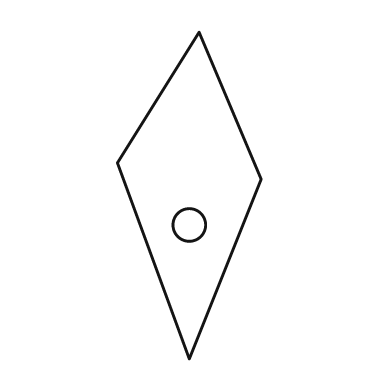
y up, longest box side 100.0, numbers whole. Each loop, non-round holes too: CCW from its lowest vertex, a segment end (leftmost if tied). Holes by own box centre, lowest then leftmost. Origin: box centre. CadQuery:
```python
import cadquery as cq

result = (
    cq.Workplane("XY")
    .moveTo(0.0, -50.0)
    .lineTo(22.0, 5.0)
    .lineTo(3.0, 50.0)
    .lineTo(-22.0, 10.0)
    .close()
    .moveTo(0.0, -9.0)
    .circle(5.0)
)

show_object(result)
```